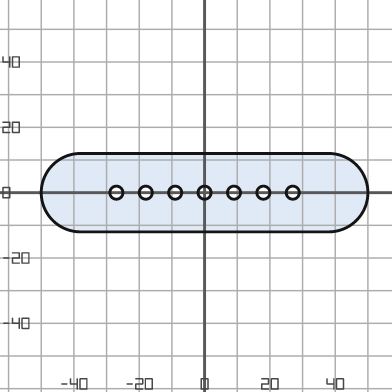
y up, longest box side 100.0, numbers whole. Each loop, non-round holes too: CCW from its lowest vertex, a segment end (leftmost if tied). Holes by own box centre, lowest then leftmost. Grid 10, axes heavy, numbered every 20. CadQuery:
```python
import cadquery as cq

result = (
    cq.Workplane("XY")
    .moveTo(-38.0, -12.0)
    .lineTo(38.0, -12.0)
    .threePointArc((50.0, 0.0), (38.0, 12.0))
    .lineTo(-38.0, 12.0)
    .threePointArc((-50.0, 0.0), (-38.0, -12.0))
    .close()
    .moveTo(-27.0, 0.0)
    .circle(2.0)
    .moveTo(-18.0, 0.0)
    .circle(2.0)
    .moveTo(-9.0, 0.0)
    .circle(2.0)
    .moveTo(0.0, 0.0)
    .circle(2.0)
    .moveTo(9.0, 0.0)
    .circle(2.0)
    .moveTo(18.0, 0.0)
    .circle(2.0)
    .moveTo(27.0, 0.0)
    .circle(2.0)
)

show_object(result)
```